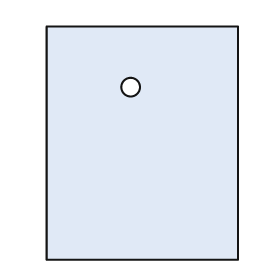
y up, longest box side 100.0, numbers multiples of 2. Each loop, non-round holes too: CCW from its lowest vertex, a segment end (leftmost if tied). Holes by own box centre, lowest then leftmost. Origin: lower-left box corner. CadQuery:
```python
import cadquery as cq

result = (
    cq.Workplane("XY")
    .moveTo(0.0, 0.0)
    .lineTo(82.0, 0.0)
    .lineTo(82.0, 100.0)
    .lineTo(0.0, 100.0)
    .close()
    .moveTo(36.0, 74.0)
    .circle(4.0)
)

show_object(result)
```